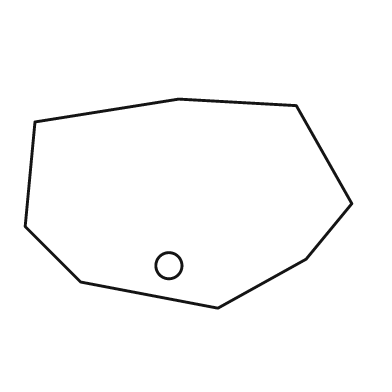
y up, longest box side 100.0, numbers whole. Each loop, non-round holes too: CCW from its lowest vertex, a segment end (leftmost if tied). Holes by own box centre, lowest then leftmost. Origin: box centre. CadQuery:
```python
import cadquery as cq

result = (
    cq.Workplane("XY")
    .moveTo(9.0, -32.0)
    .lineTo(36.0, -17.0)
    .lineTo(50.0, 0.0)
    .lineTo(33.0, 30.0)
    .lineTo(-3.0, 32.0)
    .lineTo(-47.0, 25.0)
    .lineTo(-50.0, -7.0)
    .lineTo(-33.0, -24.0)
    .close()
    .moveTo(-6.0, -19.0)
    .circle(4.0)
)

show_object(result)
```